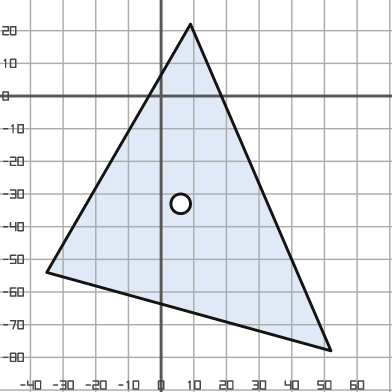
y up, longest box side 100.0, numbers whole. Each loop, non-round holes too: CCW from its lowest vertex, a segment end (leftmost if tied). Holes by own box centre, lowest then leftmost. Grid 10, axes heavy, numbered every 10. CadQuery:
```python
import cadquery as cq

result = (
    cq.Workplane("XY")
    .moveTo(52.0, -78.0)
    .lineTo(9.0, 22.0)
    .lineTo(-35.0, -54.0)
    .close()
    .moveTo(6.0, -33.0)
    .circle(3.0)
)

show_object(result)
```